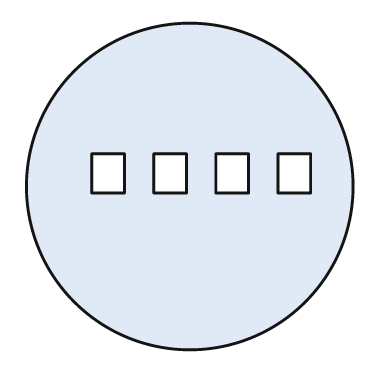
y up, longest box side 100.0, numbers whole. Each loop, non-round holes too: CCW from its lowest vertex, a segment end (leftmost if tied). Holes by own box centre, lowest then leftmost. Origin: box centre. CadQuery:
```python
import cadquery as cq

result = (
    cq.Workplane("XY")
    .moveTo(0.0, 0.0)
    .circle(50.0)
    .moveTo(-30.0, -2.0)
    .lineTo(-20.0, -2.0)
    .lineTo(-20.0, 10.0)
    .lineTo(-30.0, 10.0)
    .close()
    .moveTo(-11.0, -2.0)
    .lineTo(-1.0, -2.0)
    .lineTo(-1.0, 10.0)
    .lineTo(-11.0, 10.0)
    .close()
    .moveTo(8.0, -2.0)
    .lineTo(18.0, -2.0)
    .lineTo(18.0, 10.0)
    .lineTo(8.0, 10.0)
    .close()
    .moveTo(27.0, -2.0)
    .lineTo(37.0, -2.0)
    .lineTo(37.0, 10.0)
    .lineTo(27.0, 10.0)
    .close()
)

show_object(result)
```